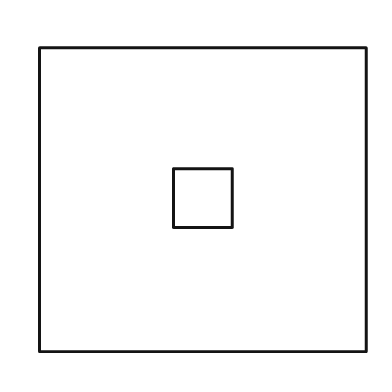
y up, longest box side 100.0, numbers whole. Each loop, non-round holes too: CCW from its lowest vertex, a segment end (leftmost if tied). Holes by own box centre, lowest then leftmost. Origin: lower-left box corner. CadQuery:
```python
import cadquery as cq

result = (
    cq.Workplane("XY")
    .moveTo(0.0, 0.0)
    .lineTo(100.0, 0.0)
    .lineTo(100.0, 93.0)
    .lineTo(0.0, 93.0)
    .close()
    .moveTo(41.0, 38.0)
    .lineTo(59.0, 38.0)
    .lineTo(59.0, 56.0)
    .lineTo(41.0, 56.0)
    .close()
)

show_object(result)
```